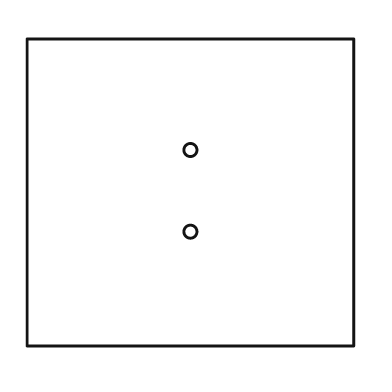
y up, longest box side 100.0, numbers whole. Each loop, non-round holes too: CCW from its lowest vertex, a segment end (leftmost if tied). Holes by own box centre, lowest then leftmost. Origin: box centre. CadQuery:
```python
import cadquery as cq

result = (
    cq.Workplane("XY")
    .moveTo(-50.0, -47.0)
    .lineTo(50.0, -47.0)
    .lineTo(50.0, 47.0)
    .lineTo(-50.0, 47.0)
    .close()
    .moveTo(0.0, -12.0)
    .circle(2.0)
    .moveTo(0.0, 13.0)
    .circle(2.0)
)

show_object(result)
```